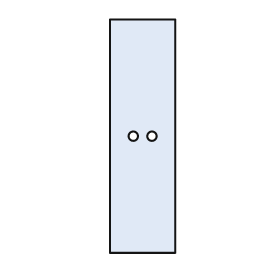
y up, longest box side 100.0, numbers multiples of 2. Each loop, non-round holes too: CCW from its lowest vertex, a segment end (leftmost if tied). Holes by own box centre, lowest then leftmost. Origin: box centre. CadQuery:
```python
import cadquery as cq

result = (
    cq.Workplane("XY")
    .moveTo(-14.0, -50.0)
    .lineTo(14.0, -50.0)
    .lineTo(14.0, 50.0)
    .lineTo(-14.0, 50.0)
    .close()
    .moveTo(-4.0, 0.0)
    .circle(2.0)
    .moveTo(4.0, 0.0)
    .circle(2.0)
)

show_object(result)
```